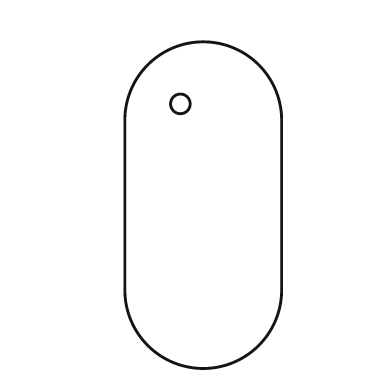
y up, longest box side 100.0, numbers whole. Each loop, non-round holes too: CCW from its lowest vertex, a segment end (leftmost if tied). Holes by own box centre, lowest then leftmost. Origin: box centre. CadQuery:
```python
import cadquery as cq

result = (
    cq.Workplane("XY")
    .moveTo(-24.0, -26.0)
    .threePointArc((0.0, -50.0), (24.0, -26.0))
    .lineTo(24.0, 26.0)
    .threePointArc((0.0, 50.0), (-24.0, 26.0))
    .close()
    .moveTo(-7.0, 31.0)
    .circle(3.0)
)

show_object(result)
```